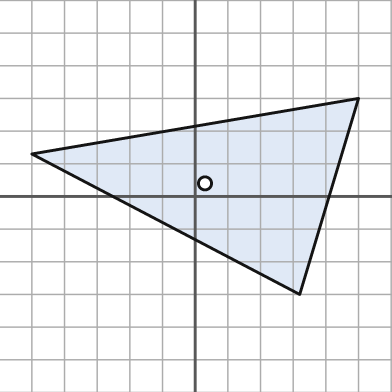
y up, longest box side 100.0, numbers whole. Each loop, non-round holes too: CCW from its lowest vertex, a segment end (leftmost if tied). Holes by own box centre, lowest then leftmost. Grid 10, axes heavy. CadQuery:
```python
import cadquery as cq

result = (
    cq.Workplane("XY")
    .moveTo(32.0, -30.0)
    .lineTo(50.0, 30.0)
    .lineTo(-50.0, 13.0)
    .close()
    .moveTo(3.0, 4.0)
    .circle(2.0)
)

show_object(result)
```